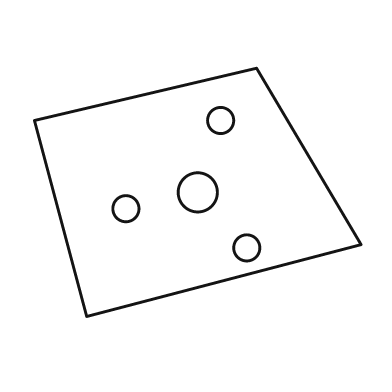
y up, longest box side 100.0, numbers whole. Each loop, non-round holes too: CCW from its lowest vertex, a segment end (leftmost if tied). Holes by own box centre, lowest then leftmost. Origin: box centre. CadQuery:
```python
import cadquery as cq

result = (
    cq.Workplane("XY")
    .moveTo(-34.0, -38.0)
    .lineTo(50.0, -16.0)
    .lineTo(18.0, 38.0)
    .lineTo(-50.0, 22.0)
    .close()
    .moveTo(15.0, -17.0)
    .circle(4.0)
    .moveTo(-22.0, -5.0)
    .circle(4.0)
    .moveTo(0.0, 0.0)
    .circle(6.0)
    .moveTo(7.0, 22.0)
    .circle(4.0)
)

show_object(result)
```